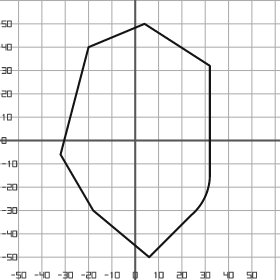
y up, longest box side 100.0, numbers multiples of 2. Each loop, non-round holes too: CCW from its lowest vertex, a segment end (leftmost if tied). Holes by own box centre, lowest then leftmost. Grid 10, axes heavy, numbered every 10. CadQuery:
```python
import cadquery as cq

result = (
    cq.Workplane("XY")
    .moveTo(6.0, -50.0)
    .lineTo(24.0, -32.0)
    .threePointArc((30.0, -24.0), (32.0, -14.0))
    .lineTo(32.0, 32.0)
    .lineTo(4.0, 50.0)
    .lineTo(-20.0, 40.0)
    .lineTo(-32.0, -6.0)
    .lineTo(-18.0, -30.0)
    .close()
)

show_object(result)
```